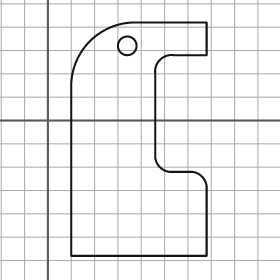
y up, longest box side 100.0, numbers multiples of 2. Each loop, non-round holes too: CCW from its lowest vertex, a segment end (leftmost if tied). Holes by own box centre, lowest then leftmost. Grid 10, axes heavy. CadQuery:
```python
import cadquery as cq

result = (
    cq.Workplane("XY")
    .moveTo(10.0, -58.0)
    .lineTo(68.0, -58.0)
    .lineTo(68.0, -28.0)
    .threePointArc((66.0, -24.0), (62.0, -22.0))
    .lineTo(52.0, -22.0)
    .threePointArc((48.0, -20.0), (46.0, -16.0))
    .lineTo(46.0, 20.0)
    .threePointArc((48.0, 26.0), (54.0, 28.0))
    .lineTo(68.0, 28.0)
    .lineTo(68.0, 42.0)
    .lineTo(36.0, 42.0)
    .threePointArc((18.0, 34.0), (10.0, 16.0))
    .close()
    .moveTo(34.0, 32.0)
    .circle(4.0)
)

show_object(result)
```